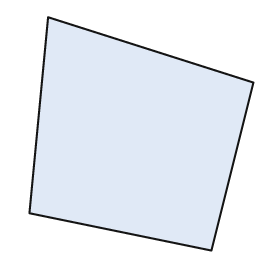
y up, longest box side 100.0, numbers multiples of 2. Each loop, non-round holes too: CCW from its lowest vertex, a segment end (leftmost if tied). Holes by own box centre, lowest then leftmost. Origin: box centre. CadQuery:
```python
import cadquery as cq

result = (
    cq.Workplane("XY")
    .moveTo(30.0, -50.0)
    .lineTo(48.0, 22.0)
    .lineTo(-40.0, 50.0)
    .lineTo(-48.0, -34.0)
    .close()
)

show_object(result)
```